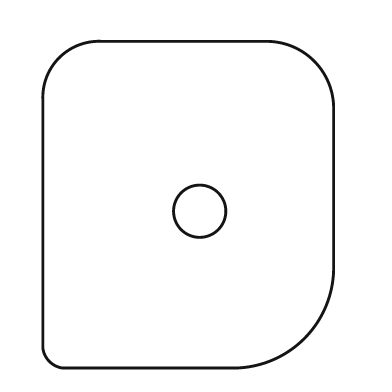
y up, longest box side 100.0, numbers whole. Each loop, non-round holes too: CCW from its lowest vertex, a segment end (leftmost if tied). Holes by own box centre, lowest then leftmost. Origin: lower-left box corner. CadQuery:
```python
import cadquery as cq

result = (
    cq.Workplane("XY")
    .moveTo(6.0, 0.0)
    .lineTo(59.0, 0.0)
    .threePointArc((80.0, 9.0), (89.0, 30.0))
    .lineTo(89.0, 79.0)
    .threePointArc((83.0, 94.0), (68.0, 100.0))
    .lineTo(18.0, 100.0)
    .threePointArc((5.0, 95.0), (0.0, 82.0))
    .lineTo(0.0, 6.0)
    .threePointArc((2.0, 2.0), (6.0, 0.0))
    .close()
    .moveTo(48.0, 48.0)
    .circle(8.0)
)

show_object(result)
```